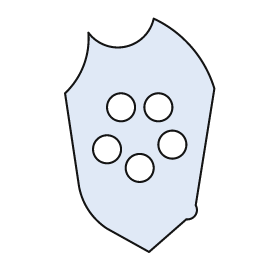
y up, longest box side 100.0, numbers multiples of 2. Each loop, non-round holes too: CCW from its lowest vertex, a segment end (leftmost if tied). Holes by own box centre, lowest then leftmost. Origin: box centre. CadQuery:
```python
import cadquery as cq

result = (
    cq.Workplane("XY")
    .moveTo(4.0, -50.0)
    .lineTo(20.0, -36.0)
    .threePointArc((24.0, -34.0), (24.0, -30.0))
    .lineTo(32.0, 20.0)
    .threePointArc((22.0, 38.0), (6.0, 50.0))
    .threePointArc((-6.0, 38.0), (-22.0, 44.0))
    .threePointArc((-24.0, 30.0), (-32.0, 18.0))
    .lineTo(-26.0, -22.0)
    .threePointArc((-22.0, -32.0), (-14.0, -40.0))
    .close()
    .moveTo(0.0, -14.0)
    .circle(6.0)
    .moveTo(-14.0, -6.0)
    .circle(6.0)
    .moveTo(14.0, -4.0)
    .circle(6.0)
    .moveTo(-8.0, 12.0)
    .circle(6.0)
    .moveTo(8.0, 12.0)
    .circle(6.0)
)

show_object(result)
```